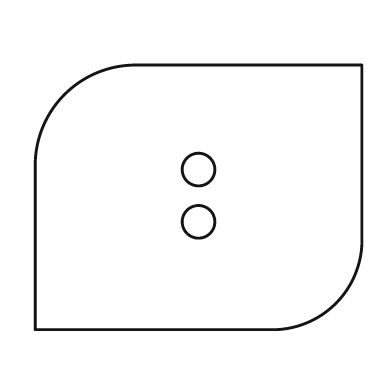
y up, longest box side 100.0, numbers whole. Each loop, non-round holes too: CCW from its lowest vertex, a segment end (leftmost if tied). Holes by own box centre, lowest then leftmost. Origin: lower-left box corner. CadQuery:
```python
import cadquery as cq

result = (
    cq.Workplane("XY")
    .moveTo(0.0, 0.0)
    .lineTo(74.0, 0.0)
    .threePointArc((92.0, 8.0), (100.0, 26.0))
    .lineTo(100.0, 81.0)
    .lineTo(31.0, 81.0)
    .threePointArc((9.0, 72.0), (0.0, 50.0))
    .close()
    .moveTo(50.0, 33.0)
    .circle(5.0)
    .moveTo(50.0, 49.0)
    .circle(5.0)
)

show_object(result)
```